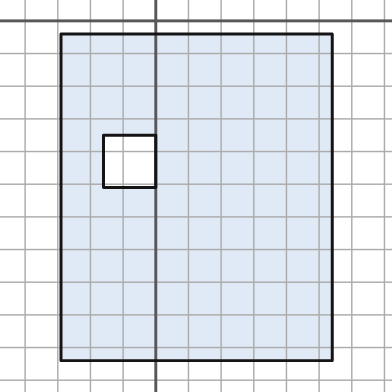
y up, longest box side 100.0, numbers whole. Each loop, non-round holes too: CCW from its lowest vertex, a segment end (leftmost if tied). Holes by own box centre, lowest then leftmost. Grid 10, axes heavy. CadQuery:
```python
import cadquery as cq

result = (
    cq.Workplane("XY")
    .moveTo(-29.0, -104.0)
    .lineTo(54.0, -104.0)
    .lineTo(54.0, -4.0)
    .lineTo(-29.0, -4.0)
    .close()
    .moveTo(-16.0, -51.0)
    .lineTo(0.0, -51.0)
    .lineTo(0.0, -35.0)
    .lineTo(-16.0, -35.0)
    .close()
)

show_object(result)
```